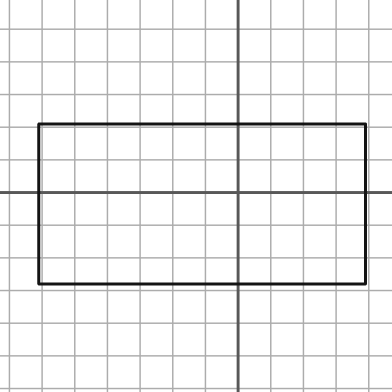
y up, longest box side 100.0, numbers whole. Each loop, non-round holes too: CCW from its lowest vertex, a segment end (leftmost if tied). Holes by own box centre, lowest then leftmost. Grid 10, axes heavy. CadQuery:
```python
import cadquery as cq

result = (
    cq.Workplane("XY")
    .moveTo(-61.0, -28.0)
    .lineTo(39.0, -28.0)
    .lineTo(39.0, 21.0)
    .lineTo(-61.0, 21.0)
    .close()
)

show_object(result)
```